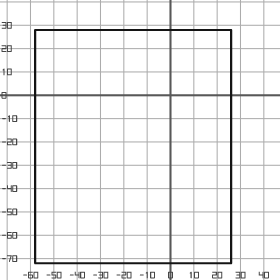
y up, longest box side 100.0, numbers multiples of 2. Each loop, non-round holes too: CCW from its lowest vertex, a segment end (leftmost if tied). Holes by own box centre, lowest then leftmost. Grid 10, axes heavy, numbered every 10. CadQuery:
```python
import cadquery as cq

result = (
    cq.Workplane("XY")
    .moveTo(-58.0, -72.0)
    .lineTo(26.0, -72.0)
    .lineTo(26.0, 28.0)
    .lineTo(-58.0, 28.0)
    .close()
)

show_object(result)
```